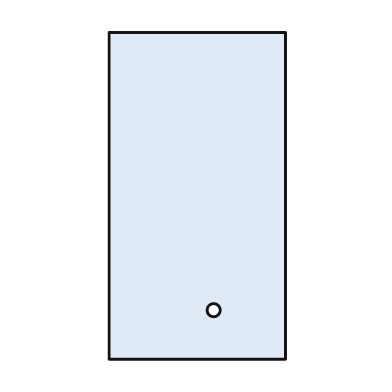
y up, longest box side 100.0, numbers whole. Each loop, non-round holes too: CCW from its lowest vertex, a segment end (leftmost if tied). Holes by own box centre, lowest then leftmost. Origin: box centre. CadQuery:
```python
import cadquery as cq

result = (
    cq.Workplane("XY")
    .moveTo(-27.0, -50.0)
    .lineTo(27.0, -50.0)
    .lineTo(27.0, 50.0)
    .lineTo(-27.0, 50.0)
    .close()
    .moveTo(5.0, -35.0)
    .circle(2.0)
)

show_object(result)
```